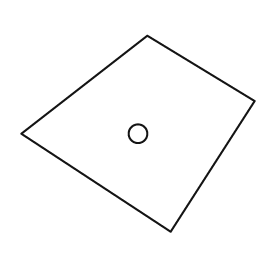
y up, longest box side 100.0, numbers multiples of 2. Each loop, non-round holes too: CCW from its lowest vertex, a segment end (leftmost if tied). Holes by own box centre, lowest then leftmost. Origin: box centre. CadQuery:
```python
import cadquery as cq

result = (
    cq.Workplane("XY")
    .moveTo(14.0, -42.0)
    .lineTo(50.0, 14.0)
    .lineTo(4.0, 42.0)
    .lineTo(-50.0, 0.0)
    .close()
    .moveTo(0.0, 0.0)
    .circle(4.0)
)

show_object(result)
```